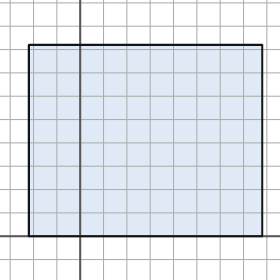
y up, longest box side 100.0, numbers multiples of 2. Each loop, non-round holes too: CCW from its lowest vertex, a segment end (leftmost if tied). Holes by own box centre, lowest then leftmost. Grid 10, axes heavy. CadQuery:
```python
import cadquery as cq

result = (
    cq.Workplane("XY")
    .moveTo(-22.0, 0.0)
    .lineTo(78.0, 0.0)
    .lineTo(78.0, 82.0)
    .lineTo(-22.0, 82.0)
    .close()
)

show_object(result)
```